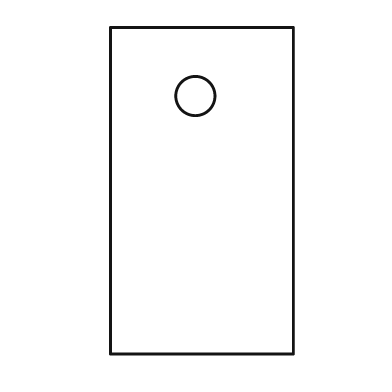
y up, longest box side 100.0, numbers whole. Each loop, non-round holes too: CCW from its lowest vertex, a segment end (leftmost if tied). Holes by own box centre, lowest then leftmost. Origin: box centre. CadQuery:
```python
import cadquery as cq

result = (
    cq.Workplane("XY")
    .moveTo(-28.0, -50.0)
    .lineTo(28.0, -50.0)
    .lineTo(28.0, 50.0)
    .lineTo(-28.0, 50.0)
    .close()
    .moveTo(-2.0, 29.0)
    .circle(6.0)
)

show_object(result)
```